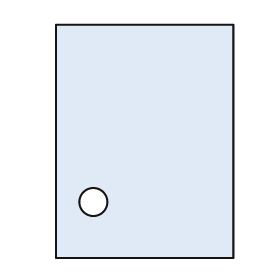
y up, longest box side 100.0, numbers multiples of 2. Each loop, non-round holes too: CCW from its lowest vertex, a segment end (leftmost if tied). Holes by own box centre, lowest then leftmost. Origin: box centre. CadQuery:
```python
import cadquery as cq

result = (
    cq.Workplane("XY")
    .moveTo(-38.0, -50.0)
    .lineTo(38.0, -50.0)
    .lineTo(38.0, 50.0)
    .lineTo(-38.0, 50.0)
    .close()
    .moveTo(-22.0, -26.0)
    .circle(6.0)
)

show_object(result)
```